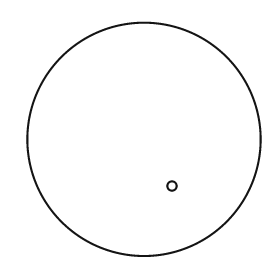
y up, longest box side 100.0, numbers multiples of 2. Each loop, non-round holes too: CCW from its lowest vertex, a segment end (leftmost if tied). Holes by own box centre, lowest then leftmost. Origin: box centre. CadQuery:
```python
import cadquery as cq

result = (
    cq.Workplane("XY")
    .moveTo(0.0, 0.0)
    .circle(50.0)
    .moveTo(12.0, -20.0)
    .circle(2.0)
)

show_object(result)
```